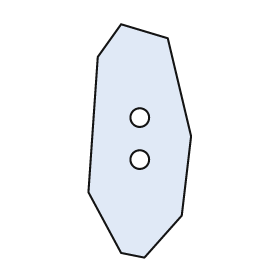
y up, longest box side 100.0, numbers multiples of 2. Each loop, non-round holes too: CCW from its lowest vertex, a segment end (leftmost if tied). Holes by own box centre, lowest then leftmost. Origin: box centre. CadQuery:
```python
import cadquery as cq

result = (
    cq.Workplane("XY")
    .moveTo(2.0, -50.0)
    .lineTo(18.0, -32.0)
    .lineTo(22.0, 2.0)
    .lineTo(12.0, 44.0)
    .lineTo(-8.0, 50.0)
    .lineTo(-18.0, 36.0)
    .lineTo(-22.0, -22.0)
    .lineTo(-8.0, -48.0)
    .close()
    .moveTo(0.0, -8.0)
    .circle(4.0)
    .moveTo(0.0, 10.0)
    .circle(4.0)
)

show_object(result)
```